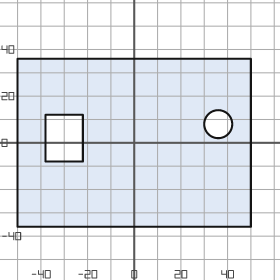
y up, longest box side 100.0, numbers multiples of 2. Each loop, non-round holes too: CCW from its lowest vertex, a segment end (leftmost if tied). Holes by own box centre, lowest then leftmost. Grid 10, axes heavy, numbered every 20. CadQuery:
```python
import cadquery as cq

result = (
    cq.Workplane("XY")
    .moveTo(-50.0, -36.0)
    .lineTo(50.0, -36.0)
    .lineTo(50.0, 36.0)
    .lineTo(-50.0, 36.0)
    .close()
    .moveTo(-38.0, -8.0)
    .lineTo(-22.0, -8.0)
    .lineTo(-22.0, 12.0)
    .lineTo(-38.0, 12.0)
    .close()
    .moveTo(36.0, 8.0)
    .circle(6.0)
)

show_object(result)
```